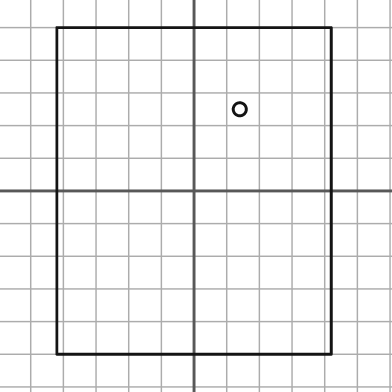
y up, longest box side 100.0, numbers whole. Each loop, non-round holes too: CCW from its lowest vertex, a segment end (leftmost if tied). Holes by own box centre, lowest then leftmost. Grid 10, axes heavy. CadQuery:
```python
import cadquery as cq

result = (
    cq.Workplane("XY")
    .moveTo(-42.0, -50.0)
    .lineTo(42.0, -50.0)
    .lineTo(42.0, 50.0)
    .lineTo(-42.0, 50.0)
    .close()
    .moveTo(14.0, 25.0)
    .circle(2.0)
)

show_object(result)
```